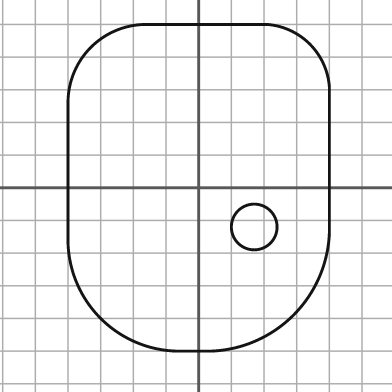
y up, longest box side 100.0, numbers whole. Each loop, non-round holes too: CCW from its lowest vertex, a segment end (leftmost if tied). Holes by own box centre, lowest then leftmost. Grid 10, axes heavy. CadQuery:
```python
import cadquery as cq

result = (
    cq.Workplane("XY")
    .moveTo(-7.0, -50.0)
    .lineTo(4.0, -50.0)
    .threePointArc((29.0, -39.0), (40.0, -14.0))
    .lineTo(40.0, 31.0)
    .threePointArc((34.0, 44.0), (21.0, 50.0))
    .lineTo(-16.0, 50.0)
    .threePointArc((-33.0, 43.0), (-40.0, 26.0))
    .lineTo(-40.0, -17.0)
    .threePointArc((-30.0, -40.0), (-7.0, -50.0))
    .close()
    .moveTo(17.0, -12.0)
    .circle(7.0)
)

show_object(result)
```